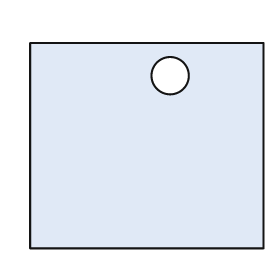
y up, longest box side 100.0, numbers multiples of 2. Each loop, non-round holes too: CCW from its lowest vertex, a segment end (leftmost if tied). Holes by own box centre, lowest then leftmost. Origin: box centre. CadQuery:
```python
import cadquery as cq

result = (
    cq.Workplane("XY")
    .moveTo(-50.0, -44.0)
    .lineTo(50.0, -44.0)
    .lineTo(50.0, 44.0)
    .lineTo(-50.0, 44.0)
    .close()
    .moveTo(10.0, 30.0)
    .circle(8.0)
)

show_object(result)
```